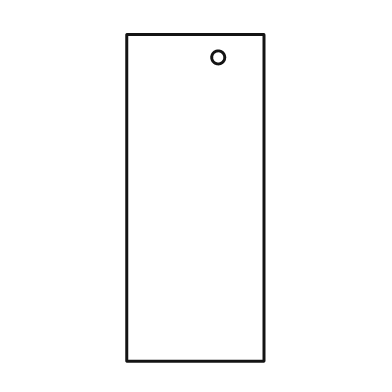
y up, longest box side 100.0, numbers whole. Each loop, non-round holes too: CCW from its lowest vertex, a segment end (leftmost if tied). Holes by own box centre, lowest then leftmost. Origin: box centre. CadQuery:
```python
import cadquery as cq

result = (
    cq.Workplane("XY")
    .moveTo(-21.0, -50.0)
    .lineTo(21.0, -50.0)
    .lineTo(21.0, 50.0)
    .lineTo(-21.0, 50.0)
    .close()
    .moveTo(7.0, 43.0)
    .circle(2.0)
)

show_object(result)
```